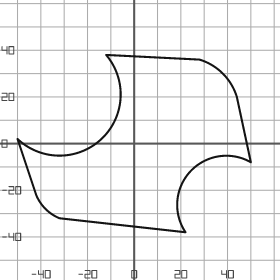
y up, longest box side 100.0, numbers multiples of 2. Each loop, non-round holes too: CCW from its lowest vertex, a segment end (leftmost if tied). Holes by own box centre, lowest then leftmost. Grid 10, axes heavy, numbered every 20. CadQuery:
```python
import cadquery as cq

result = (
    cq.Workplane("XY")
    .moveTo(22.0, -38.0)
    .threePointArc((24.0, -12.0), (50.0, -8.0))
    .lineTo(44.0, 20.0)
    .threePointArc((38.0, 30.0), (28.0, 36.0))
    .lineTo(-12.0, 38.0)
    .threePointArc((-14.0, 2.0), (-50.0, 2.0))
    .lineTo(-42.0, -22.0)
    .threePointArc((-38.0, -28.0), (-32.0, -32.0))
    .close()
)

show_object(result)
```